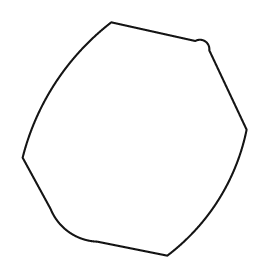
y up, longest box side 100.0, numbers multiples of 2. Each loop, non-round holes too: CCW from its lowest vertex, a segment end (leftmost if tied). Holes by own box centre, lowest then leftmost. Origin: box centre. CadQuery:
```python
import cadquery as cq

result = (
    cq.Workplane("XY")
    .moveTo(14.0, -50.0)
    .threePointArc((36.0, -26.0), (48.0, 4.0))
    .lineTo(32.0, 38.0)
    .threePointArc((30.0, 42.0), (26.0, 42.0))
    .lineTo(-10.0, 50.0)
    .threePointArc((-34.0, 24.0), (-48.0, -8.0))
    .lineTo(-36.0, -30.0)
    .threePointArc((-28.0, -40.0), (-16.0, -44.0))
    .close()
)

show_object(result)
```